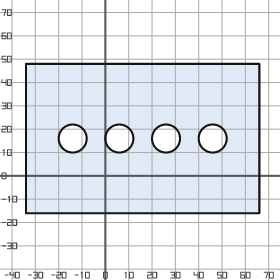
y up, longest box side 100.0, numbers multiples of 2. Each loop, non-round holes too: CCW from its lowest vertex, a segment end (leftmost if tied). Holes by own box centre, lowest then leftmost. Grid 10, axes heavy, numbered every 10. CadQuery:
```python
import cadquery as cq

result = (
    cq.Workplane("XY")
    .moveTo(-34.0, -16.0)
    .lineTo(66.0, -16.0)
    .lineTo(66.0, 48.0)
    .lineTo(-34.0, 48.0)
    .close()
    .moveTo(-14.0, 16.0)
    .circle(6.0)
    .moveTo(6.0, 16.0)
    .circle(6.0)
    .moveTo(26.0, 16.0)
    .circle(6.0)
    .moveTo(46.0, 16.0)
    .circle(6.0)
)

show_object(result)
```